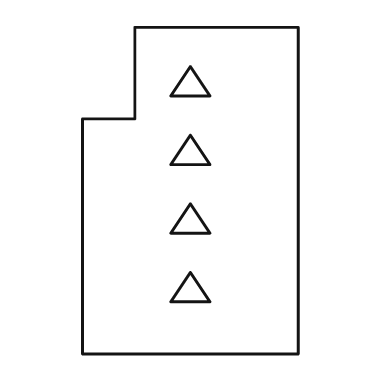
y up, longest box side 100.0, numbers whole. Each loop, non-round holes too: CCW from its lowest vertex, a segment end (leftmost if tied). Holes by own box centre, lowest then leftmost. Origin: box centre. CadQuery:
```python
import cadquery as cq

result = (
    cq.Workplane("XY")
    .moveTo(-33.0, -50.0)
    .lineTo(33.0, -50.0)
    .lineTo(33.0, 50.0)
    .lineTo(-17.0, 50.0)
    .lineTo(-17.0, 22.0)
    .lineTo(-33.0, 22.0)
    .close()
    .moveTo(-6.0, -34.0)
    .lineTo(6.0, -34.0)
    .lineTo(0.0, -25.0)
    .close()
    .moveTo(-6.0, -13.0)
    .lineTo(6.0, -13.0)
    .lineTo(0.0, -4.0)
    .close()
    .moveTo(-6.0, 8.0)
    .lineTo(6.0, 8.0)
    .lineTo(0.0, 17.0)
    .close()
    .moveTo(-6.0, 29.0)
    .lineTo(6.0, 29.0)
    .lineTo(0.0, 38.0)
    .close()
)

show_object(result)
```